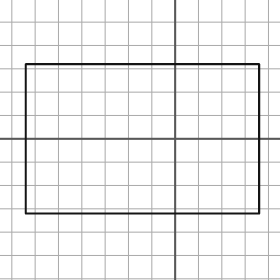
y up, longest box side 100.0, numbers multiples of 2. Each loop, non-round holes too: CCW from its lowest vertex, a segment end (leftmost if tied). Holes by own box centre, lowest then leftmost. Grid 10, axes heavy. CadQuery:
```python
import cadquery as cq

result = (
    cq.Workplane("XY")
    .moveTo(-64.0, -32.0)
    .lineTo(36.0, -32.0)
    .lineTo(36.0, 32.0)
    .lineTo(-64.0, 32.0)
    .close()
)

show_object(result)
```